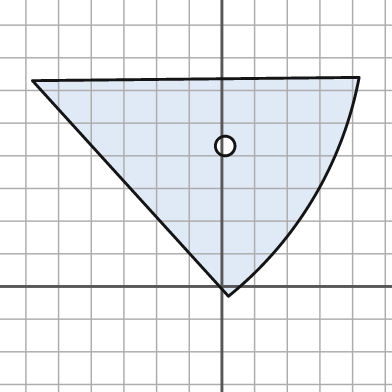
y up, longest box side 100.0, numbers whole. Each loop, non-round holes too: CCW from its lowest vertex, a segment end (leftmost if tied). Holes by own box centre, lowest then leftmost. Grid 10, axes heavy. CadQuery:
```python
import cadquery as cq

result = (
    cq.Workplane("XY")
    .moveTo(2.0, -3.0)
    .threePointArc((28.0, 27.0), (42.0, 64.0))
    .lineTo(-58.0, 63.0)
    .close()
    .moveTo(1.0, 43.0)
    .circle(3.0)
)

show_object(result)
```